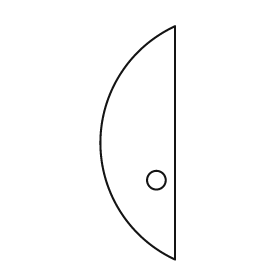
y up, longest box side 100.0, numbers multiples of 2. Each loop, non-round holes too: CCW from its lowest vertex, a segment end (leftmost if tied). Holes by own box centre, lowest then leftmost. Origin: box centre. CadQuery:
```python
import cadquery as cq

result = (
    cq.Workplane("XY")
    .moveTo(16.0, -50.0)
    .lineTo(16.0, 50.0)
    .threePointArc((-16.0, 0.0), (16.0, -50.0))
    .close()
    .moveTo(8.0, -16.0)
    .circle(4.0)
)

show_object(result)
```